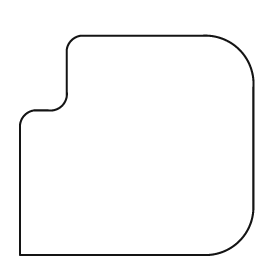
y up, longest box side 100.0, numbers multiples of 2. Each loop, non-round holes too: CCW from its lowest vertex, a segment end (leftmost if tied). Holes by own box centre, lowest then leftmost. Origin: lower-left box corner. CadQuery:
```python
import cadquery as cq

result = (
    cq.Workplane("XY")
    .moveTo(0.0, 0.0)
    .lineTo(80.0, 0.0)
    .threePointArc((94.0, 6.0), (100.0, 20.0))
    .lineTo(100.0, 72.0)
    .threePointArc((94.0, 88.0), (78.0, 94.0))
    .lineTo(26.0, 94.0)
    .threePointArc((22.0, 92.0), (20.0, 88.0))
    .lineTo(20.0, 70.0)
    .threePointArc((18.0, 64.0), (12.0, 62.0))
    .lineTo(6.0, 62.0)
    .threePointArc((2.0, 60.0), (0.0, 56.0))
    .close()
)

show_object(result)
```